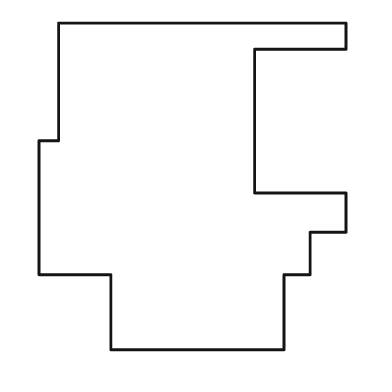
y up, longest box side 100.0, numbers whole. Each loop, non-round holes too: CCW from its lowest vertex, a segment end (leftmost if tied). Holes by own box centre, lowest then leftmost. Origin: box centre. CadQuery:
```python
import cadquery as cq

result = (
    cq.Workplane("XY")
    .moveTo(-25.0, -50.0)
    .lineTo(28.0, -50.0)
    .lineTo(28.0, -27.0)
    .lineTo(36.0, -27.0)
    .lineTo(36.0, -14.0)
    .lineTo(47.0, -14.0)
    .lineTo(47.0, -2.0)
    .lineTo(19.0, -2.0)
    .lineTo(19.0, 42.0)
    .lineTo(47.0, 42.0)
    .lineTo(47.0, 50.0)
    .lineTo(-41.0, 50.0)
    .lineTo(-41.0, 14.0)
    .lineTo(-47.0, 14.0)
    .lineTo(-47.0, -27.0)
    .lineTo(-25.0, -27.0)
    .close()
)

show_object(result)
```